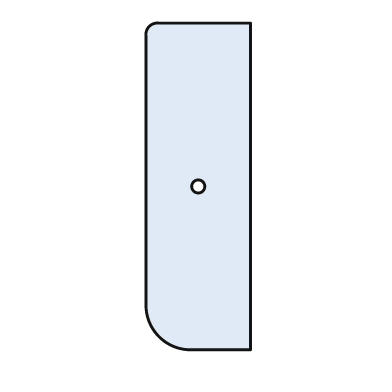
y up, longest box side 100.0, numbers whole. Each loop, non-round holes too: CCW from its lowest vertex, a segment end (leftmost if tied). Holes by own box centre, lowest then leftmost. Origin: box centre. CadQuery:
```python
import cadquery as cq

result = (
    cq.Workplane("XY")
    .moveTo(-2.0, -50.0)
    .lineTo(16.0, -50.0)
    .lineTo(16.0, 50.0)
    .lineTo(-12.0, 50.0)
    .threePointArc((-15.0, 49.0), (-16.0, 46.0))
    .lineTo(-16.0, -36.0)
    .threePointArc((-12.0, -46.0), (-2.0, -50.0))
    .close()
    .moveTo(0.0, 0.0)
    .circle(2.0)
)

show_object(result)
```